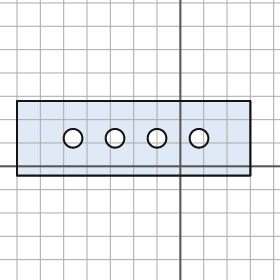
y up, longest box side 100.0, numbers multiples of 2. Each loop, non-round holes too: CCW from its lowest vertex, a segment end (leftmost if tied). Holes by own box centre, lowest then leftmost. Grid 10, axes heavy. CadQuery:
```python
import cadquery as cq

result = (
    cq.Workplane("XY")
    .moveTo(-70.0, -4.0)
    .lineTo(30.0, -4.0)
    .lineTo(30.0, 28.0)
    .lineTo(-70.0, 28.0)
    .close()
    .moveTo(-46.0, 12.0)
    .circle(4.0)
    .moveTo(-28.0, 12.0)
    .circle(4.0)
    .moveTo(-10.0, 12.0)
    .circle(4.0)
    .moveTo(8.0, 12.0)
    .circle(4.0)
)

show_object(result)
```